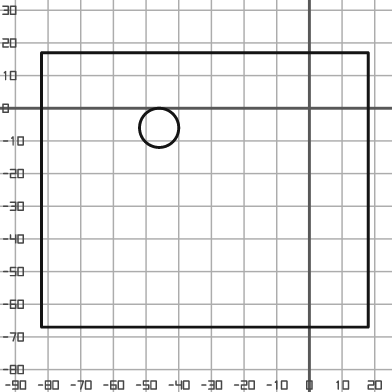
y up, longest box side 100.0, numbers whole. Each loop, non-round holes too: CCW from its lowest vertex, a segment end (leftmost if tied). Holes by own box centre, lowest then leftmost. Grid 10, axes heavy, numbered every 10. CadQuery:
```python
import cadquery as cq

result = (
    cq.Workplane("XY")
    .moveTo(-82.0, -67.0)
    .lineTo(18.0, -67.0)
    .lineTo(18.0, 17.0)
    .lineTo(-82.0, 17.0)
    .close()
    .moveTo(-46.0, -6.0)
    .circle(6.0)
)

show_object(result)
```